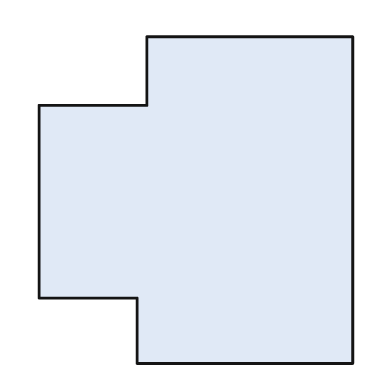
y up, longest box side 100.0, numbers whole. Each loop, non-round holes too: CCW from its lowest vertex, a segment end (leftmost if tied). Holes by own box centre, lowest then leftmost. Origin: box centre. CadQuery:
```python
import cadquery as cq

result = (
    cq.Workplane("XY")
    .moveTo(-18.0, -50.0)
    .lineTo(48.0, -50.0)
    .lineTo(48.0, 50.0)
    .lineTo(-15.0, 50.0)
    .lineTo(-15.0, 29.0)
    .lineTo(-48.0, 29.0)
    .lineTo(-48.0, -30.0)
    .lineTo(-18.0, -30.0)
    .close()
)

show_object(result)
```